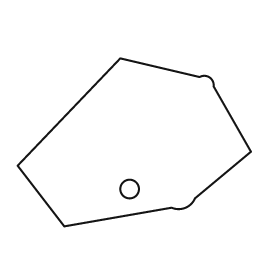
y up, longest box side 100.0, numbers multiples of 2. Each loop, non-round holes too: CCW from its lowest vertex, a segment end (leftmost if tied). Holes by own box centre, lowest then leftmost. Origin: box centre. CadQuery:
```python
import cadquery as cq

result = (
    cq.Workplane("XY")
    .moveTo(-30.0, -36.0)
    .lineTo(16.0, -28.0)
    .threePointArc((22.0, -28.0), (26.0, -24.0))
    .lineTo(50.0, -4.0)
    .lineTo(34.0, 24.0)
    .threePointArc((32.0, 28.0), (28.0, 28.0))
    .lineTo(-6.0, 36.0)
    .lineTo(-50.0, -10.0)
    .close()
    .moveTo(-2.0, -20.0)
    .circle(4.0)
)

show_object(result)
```